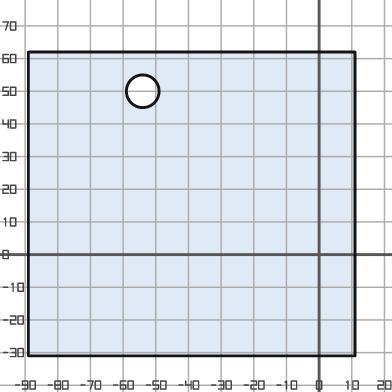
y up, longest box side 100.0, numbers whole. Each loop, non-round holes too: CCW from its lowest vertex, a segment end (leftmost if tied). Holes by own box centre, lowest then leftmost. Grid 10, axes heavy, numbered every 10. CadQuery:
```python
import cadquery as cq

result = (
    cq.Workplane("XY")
    .moveTo(-89.0, -31.0)
    .lineTo(11.0, -31.0)
    .lineTo(11.0, 62.0)
    .lineTo(-89.0, 62.0)
    .close()
    .moveTo(-54.0, 50.0)
    .circle(5.0)
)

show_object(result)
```